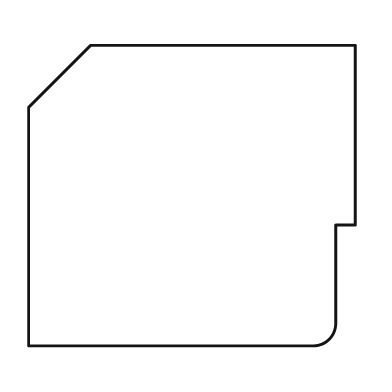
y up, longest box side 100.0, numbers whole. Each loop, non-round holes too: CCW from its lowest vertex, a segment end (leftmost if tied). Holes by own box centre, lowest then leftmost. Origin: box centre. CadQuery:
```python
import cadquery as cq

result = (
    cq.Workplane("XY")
    .moveTo(-50.0, -46.0)
    .lineTo(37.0, -46.0)
    .threePointArc((42.0, -44.0), (44.0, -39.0))
    .lineTo(44.0, -9.0)
    .lineTo(50.0, -9.0)
    .lineTo(50.0, 46.0)
    .lineTo(-31.0, 46.0)
    .lineTo(-50.0, 27.0)
    .close()
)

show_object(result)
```